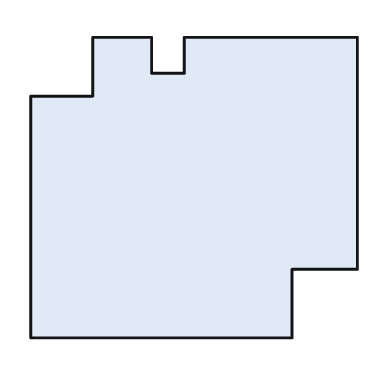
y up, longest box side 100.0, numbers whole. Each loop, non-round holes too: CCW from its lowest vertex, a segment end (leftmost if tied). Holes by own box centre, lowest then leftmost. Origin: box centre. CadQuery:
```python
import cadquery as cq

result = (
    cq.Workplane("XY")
    .moveTo(-50.0, -46.0)
    .lineTo(30.0, -46.0)
    .lineTo(30.0, -25.0)
    .lineTo(50.0, -25.0)
    .lineTo(50.0, 46.0)
    .lineTo(-3.0, 46.0)
    .lineTo(-3.0, 35.0)
    .lineTo(-13.0, 35.0)
    .lineTo(-13.0, 46.0)
    .lineTo(-31.0, 46.0)
    .lineTo(-31.0, 28.0)
    .lineTo(-50.0, 28.0)
    .close()
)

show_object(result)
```